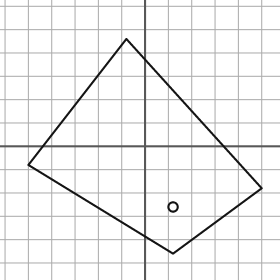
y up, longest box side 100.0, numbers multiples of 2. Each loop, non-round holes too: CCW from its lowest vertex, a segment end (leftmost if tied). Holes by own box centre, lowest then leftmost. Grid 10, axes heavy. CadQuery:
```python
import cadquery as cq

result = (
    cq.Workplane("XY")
    .moveTo(12.0, -46.0)
    .lineTo(50.0, -18.0)
    .lineTo(-8.0, 46.0)
    .lineTo(-50.0, -8.0)
    .close()
    .moveTo(12.0, -26.0)
    .circle(2.0)
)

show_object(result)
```